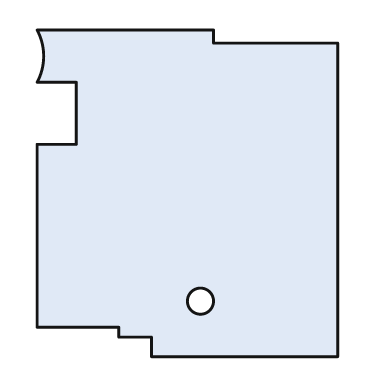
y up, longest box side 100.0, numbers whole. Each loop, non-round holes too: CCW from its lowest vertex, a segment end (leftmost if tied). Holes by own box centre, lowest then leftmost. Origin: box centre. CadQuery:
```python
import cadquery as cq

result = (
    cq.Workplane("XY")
    .moveTo(-11.0, -50.0)
    .lineTo(46.0, -50.0)
    .lineTo(46.0, 46.0)
    .lineTo(8.0, 46.0)
    .lineTo(8.0, 50.0)
    .lineTo(-46.0, 50.0)
    .threePointArc((-44.0, 42.0), (-46.0, 34.0))
    .lineTo(-34.0, 34.0)
    .lineTo(-34.0, 15.0)
    .lineTo(-46.0, 15.0)
    .lineTo(-46.0, -41.0)
    .lineTo(-21.0, -41.0)
    .lineTo(-21.0, -44.0)
    .lineTo(-11.0, -44.0)
    .close()
    .moveTo(4.0, -33.0)
    .circle(4.0)
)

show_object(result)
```